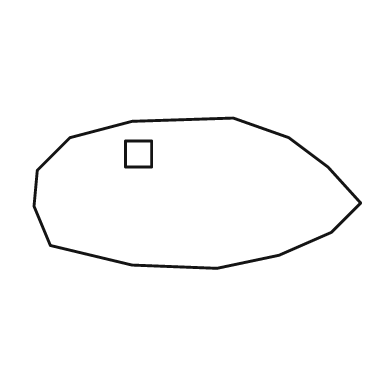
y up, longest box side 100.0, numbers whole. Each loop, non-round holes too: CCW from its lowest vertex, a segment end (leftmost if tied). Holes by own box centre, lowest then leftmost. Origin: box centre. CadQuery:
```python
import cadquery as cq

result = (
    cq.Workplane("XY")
    .moveTo(6.0, -23.0)
    .lineTo(25.0, -19.0)
    .lineTo(41.0, -12.0)
    .lineTo(50.0, -3.0)
    .lineTo(40.0, 8.0)
    .lineTo(28.0, 17.0)
    .lineTo(11.0, 23.0)
    .lineTo(-20.0, 22.0)
    .lineTo(-39.0, 17.0)
    .lineTo(-49.0, 7.0)
    .lineTo(-50.0, -4.0)
    .lineTo(-45.0, -16.0)
    .lineTo(-20.0, -22.0)
    .close()
    .moveTo(-22.0, 8.0)
    .lineTo(-14.0, 8.0)
    .lineTo(-14.0, 16.0)
    .lineTo(-22.0, 16.0)
    .close()
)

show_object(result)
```